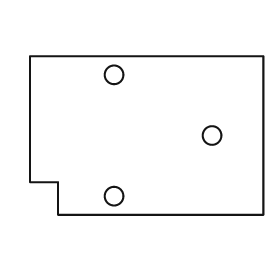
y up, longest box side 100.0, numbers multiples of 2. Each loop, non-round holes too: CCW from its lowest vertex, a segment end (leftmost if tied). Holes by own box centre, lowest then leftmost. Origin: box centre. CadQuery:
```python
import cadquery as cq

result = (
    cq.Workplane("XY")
    .moveTo(-38.0, -34.0)
    .lineTo(50.0, -34.0)
    .lineTo(50.0, 34.0)
    .lineTo(-50.0, 34.0)
    .lineTo(-50.0, -20.0)
    .lineTo(-38.0, -20.0)
    .close()
    .moveTo(-14.0, -26.0)
    .circle(4.0)
    .moveTo(28.0, 0.0)
    .circle(4.0)
    .moveTo(-14.0, 26.0)
    .circle(4.0)
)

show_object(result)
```